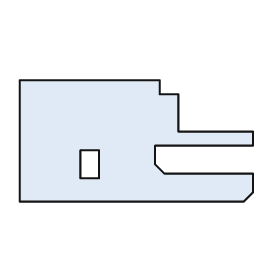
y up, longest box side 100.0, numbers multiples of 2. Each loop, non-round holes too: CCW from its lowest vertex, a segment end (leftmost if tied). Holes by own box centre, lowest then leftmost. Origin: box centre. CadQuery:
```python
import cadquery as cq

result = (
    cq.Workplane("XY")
    .moveTo(-50.0, -26.0)
    .lineTo(46.0, -26.0)
    .lineTo(50.0, -22.0)
    .lineTo(50.0, -14.0)
    .lineTo(12.0, -14.0)
    .lineTo(8.0, -10.0)
    .lineTo(8.0, -2.0)
    .lineTo(50.0, -2.0)
    .lineTo(50.0, 4.0)
    .lineTo(18.0, 4.0)
    .lineTo(18.0, 20.0)
    .lineTo(10.0, 20.0)
    .lineTo(10.0, 26.0)
    .lineTo(-50.0, 26.0)
    .close()
    .moveTo(-24.0, -16.0)
    .lineTo(-16.0, -16.0)
    .lineTo(-16.0, -4.0)
    .lineTo(-24.0, -4.0)
    .close()
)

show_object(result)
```